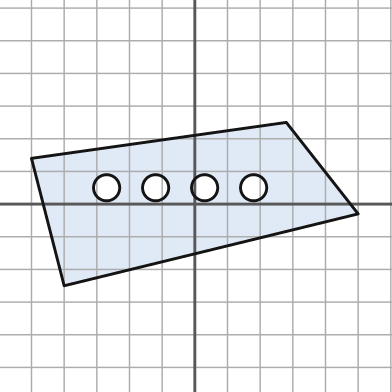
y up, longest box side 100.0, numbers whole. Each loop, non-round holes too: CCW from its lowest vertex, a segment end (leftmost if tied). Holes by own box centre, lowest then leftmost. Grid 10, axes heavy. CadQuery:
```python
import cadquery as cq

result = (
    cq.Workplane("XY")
    .moveTo(-40.0, -25.0)
    .lineTo(50.0, -3.0)
    .lineTo(28.0, 25.0)
    .lineTo(-50.0, 14.0)
    .close()
    .moveTo(-27.0, 5.0)
    .circle(4.0)
    .moveTo(-12.0, 5.0)
    .circle(4.0)
    .moveTo(3.0, 5.0)
    .circle(4.0)
    .moveTo(18.0, 5.0)
    .circle(4.0)
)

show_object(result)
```